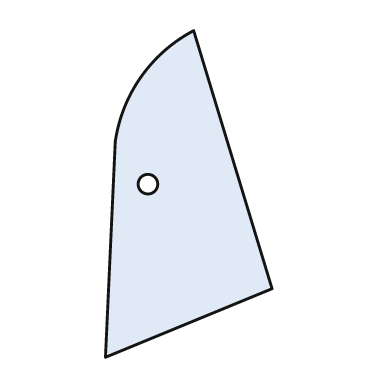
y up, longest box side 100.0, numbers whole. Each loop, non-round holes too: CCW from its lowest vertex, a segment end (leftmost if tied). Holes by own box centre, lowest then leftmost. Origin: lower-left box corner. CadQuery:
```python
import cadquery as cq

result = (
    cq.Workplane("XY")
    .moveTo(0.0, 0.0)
    .lineTo(51.0, 21.0)
    .lineTo(27.0, 100.0)
    .threePointArc((11.0, 86.0), (3.0, 66.0))
    .close()
    .moveTo(13.0, 53.0)
    .circle(3.0)
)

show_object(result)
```